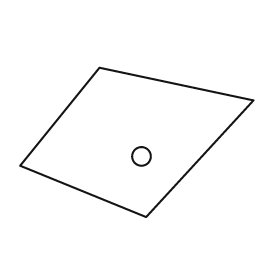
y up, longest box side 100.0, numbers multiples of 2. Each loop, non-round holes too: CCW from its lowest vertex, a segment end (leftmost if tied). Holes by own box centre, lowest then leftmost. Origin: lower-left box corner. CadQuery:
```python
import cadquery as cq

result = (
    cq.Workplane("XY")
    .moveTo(54.0, 0.0)
    .lineTo(100.0, 50.0)
    .lineTo(34.0, 64.0)
    .lineTo(0.0, 22.0)
    .close()
    .moveTo(52.0, 26.0)
    .circle(4.0)
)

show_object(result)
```